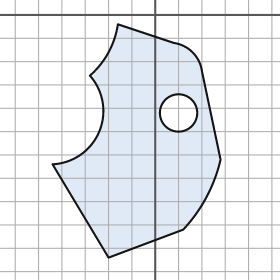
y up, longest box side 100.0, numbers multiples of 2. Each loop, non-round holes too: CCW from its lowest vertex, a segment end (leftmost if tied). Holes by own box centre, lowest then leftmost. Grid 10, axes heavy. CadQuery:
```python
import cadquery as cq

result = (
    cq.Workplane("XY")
    .moveTo(-20.0, -104.0)
    .lineTo(12.0, -92.0)
    .threePointArc((22.0, -78.0), (28.0, -62.0))
    .lineTo(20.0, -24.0)
    .threePointArc((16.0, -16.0), (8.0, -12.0))
    .lineTo(-16.0, -4.0)
    .threePointArc((-20.0, -16.0), (-28.0, -26.0))
    .threePointArc((-24.0, -50.0), (-44.0, -64.0))
    .close()
    .moveTo(10.0, -42.0)
    .circle(8.0)
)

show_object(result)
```